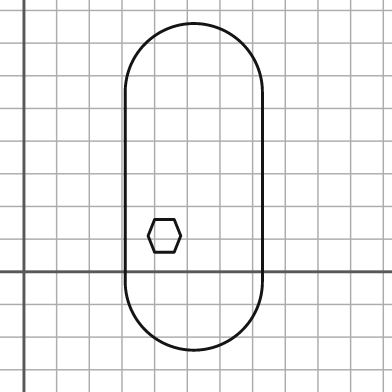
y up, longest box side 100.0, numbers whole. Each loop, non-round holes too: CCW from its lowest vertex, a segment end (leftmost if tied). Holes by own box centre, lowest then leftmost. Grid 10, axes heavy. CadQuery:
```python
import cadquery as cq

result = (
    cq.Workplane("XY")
    .moveTo(31.0, -3.0)
    .threePointArc((52.0, -24.0), (73.0, -3.0))
    .lineTo(73.0, 55.0)
    .threePointArc((52.0, 76.0), (31.0, 55.0))
    .close()
    .moveTo(40.0, 6.0)
    .lineTo(46.0, 6.0)
    .lineTo(48.0, 11.0)
    .lineTo(46.0, 16.0)
    .lineTo(40.0, 16.0)
    .lineTo(38.0, 11.0)
    .close()
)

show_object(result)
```